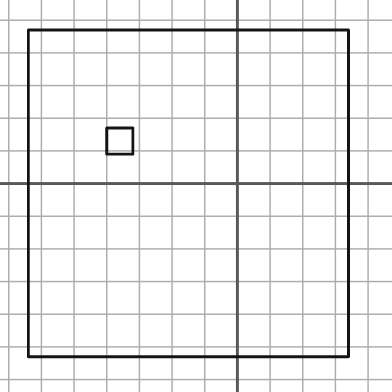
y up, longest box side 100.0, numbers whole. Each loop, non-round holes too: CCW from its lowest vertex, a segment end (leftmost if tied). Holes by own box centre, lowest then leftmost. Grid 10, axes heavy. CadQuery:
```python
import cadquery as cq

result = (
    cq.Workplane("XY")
    .moveTo(-64.0, -53.0)
    .lineTo(34.0, -53.0)
    .lineTo(34.0, 47.0)
    .lineTo(-64.0, 47.0)
    .close()
    .moveTo(-40.0, 9.0)
    .lineTo(-32.0, 9.0)
    .lineTo(-32.0, 17.0)
    .lineTo(-40.0, 17.0)
    .close()
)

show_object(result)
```